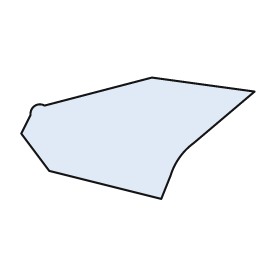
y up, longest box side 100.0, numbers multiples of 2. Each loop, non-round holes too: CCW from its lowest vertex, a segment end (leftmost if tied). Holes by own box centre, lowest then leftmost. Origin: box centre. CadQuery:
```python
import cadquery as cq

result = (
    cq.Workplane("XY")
    .moveTo(10.0, -26.0)
    .lineTo(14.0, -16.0)
    .threePointArc((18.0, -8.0), (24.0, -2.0))
    .lineTo(50.0, 20.0)
    .lineTo(6.0, 26.0)
    .lineTo(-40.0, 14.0)
    .threePointArc((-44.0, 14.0), (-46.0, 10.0))
    .lineTo(-50.0, 2.0)
    .lineTo(-38.0, -14.0)
    .close()
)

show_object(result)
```